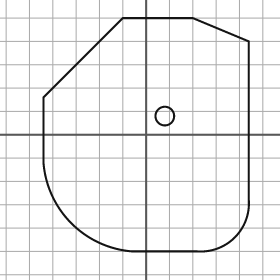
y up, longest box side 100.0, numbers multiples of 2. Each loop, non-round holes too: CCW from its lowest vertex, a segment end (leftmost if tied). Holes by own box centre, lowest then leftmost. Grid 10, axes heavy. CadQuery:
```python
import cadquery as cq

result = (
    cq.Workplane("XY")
    .moveTo(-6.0, -50.0)
    .lineTo(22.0, -50.0)
    .threePointArc((38.0, -44.0), (44.0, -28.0))
    .lineTo(44.0, 40.0)
    .lineTo(20.0, 50.0)
    .lineTo(-10.0, 50.0)
    .lineTo(-44.0, 16.0)
    .lineTo(-44.0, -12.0)
    .threePointArc((-32.0, -38.0), (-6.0, -50.0))
    .close()
    .moveTo(8.0, 8.0)
    .circle(4.0)
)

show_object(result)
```